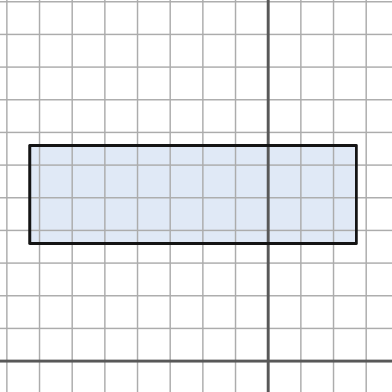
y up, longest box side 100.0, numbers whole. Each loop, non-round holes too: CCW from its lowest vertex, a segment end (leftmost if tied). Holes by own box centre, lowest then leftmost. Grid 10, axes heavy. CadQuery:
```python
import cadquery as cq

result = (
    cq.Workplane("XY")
    .moveTo(-73.0, 36.0)
    .lineTo(27.0, 36.0)
    .lineTo(27.0, 66.0)
    .lineTo(-73.0, 66.0)
    .close()
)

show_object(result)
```